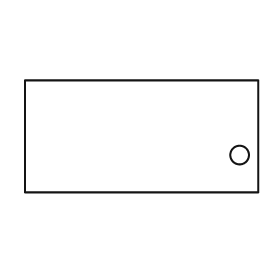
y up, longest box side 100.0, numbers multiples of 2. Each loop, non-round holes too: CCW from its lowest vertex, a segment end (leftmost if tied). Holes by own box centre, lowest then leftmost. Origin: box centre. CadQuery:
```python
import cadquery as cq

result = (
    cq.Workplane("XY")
    .moveTo(-50.0, -24.0)
    .lineTo(50.0, -24.0)
    .lineTo(50.0, 24.0)
    .lineTo(-50.0, 24.0)
    .close()
    .moveTo(42.0, -8.0)
    .circle(4.0)
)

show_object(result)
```